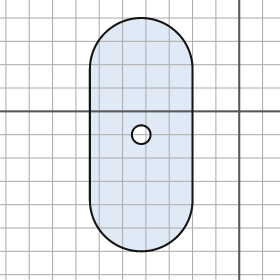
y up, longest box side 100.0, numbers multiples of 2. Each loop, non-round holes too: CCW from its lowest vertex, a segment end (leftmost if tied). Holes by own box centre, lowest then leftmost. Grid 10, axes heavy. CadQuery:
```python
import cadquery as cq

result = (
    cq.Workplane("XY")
    .moveTo(-64.0, -38.0)
    .threePointArc((-42.0, -60.0), (-20.0, -38.0))
    .lineTo(-20.0, 18.0)
    .threePointArc((-42.0, 40.0), (-64.0, 18.0))
    .close()
    .moveTo(-42.0, -10.0)
    .circle(4.0)
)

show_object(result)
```